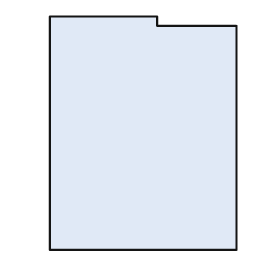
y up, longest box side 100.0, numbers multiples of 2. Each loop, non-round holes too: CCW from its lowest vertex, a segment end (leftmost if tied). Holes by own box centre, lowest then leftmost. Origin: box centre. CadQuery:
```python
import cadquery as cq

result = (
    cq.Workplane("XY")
    .moveTo(-40.0, -50.0)
    .lineTo(40.0, -50.0)
    .lineTo(40.0, 46.0)
    .lineTo(6.0, 46.0)
    .lineTo(6.0, 50.0)
    .lineTo(-40.0, 50.0)
    .close()
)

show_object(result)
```